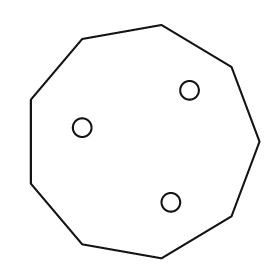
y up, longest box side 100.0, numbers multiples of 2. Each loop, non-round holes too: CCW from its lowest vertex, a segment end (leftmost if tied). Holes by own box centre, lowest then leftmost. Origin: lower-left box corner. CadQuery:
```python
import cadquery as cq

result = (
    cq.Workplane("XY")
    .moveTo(56.0, 0.0)
    .lineTo(86.0, 18.0)
    .lineTo(98.0, 50.0)
    .lineTo(86.0, 82.0)
    .lineTo(56.0, 100.0)
    .lineTo(22.0, 94.0)
    .lineTo(0.0, 68.0)
    .lineTo(0.0, 32.0)
    .lineTo(22.0, 6.0)
    .close()
    .moveTo(60.0, 24.0)
    .circle(4.0)
    .moveTo(22.0, 56.0)
    .circle(4.0)
    .moveTo(68.0, 72.0)
    .circle(4.0)
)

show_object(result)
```